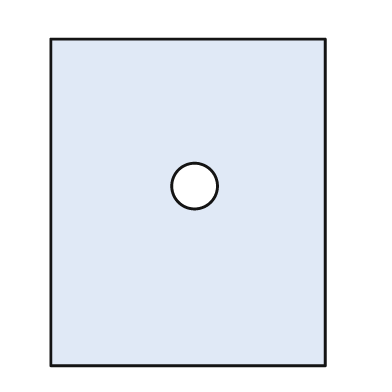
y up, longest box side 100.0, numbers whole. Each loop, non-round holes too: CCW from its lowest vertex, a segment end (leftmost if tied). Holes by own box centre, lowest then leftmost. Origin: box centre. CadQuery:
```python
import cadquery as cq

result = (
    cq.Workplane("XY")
    .moveTo(-42.0, -50.0)
    .lineTo(42.0, -50.0)
    .lineTo(42.0, 50.0)
    .lineTo(-42.0, 50.0)
    .close()
    .moveTo(2.0, 5.0)
    .circle(7.0)
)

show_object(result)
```